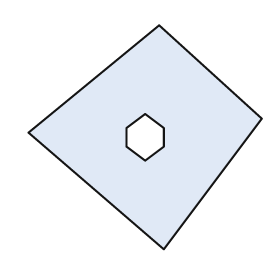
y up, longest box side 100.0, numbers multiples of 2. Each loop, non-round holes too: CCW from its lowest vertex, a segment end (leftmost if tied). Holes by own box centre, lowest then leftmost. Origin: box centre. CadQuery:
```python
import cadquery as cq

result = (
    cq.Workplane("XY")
    .moveTo(8.0, -48.0)
    .lineTo(50.0, 8.0)
    .lineTo(6.0, 48.0)
    .lineTo(-50.0, 2.0)
    .close()
    .moveTo(0.0, -10.0)
    .lineTo(8.0, -4.0)
    .lineTo(8.0, 4.0)
    .lineTo(0.0, 10.0)
    .lineTo(-8.0, 4.0)
    .lineTo(-8.0, -4.0)
    .close()
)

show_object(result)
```